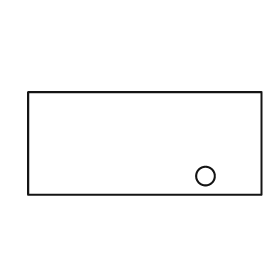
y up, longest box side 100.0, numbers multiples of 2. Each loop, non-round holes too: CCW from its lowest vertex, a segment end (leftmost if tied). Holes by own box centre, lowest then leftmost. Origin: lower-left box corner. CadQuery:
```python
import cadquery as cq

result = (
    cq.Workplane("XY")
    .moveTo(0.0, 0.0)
    .lineTo(100.0, 0.0)
    .lineTo(100.0, 44.0)
    .lineTo(0.0, 44.0)
    .close()
    .moveTo(76.0, 8.0)
    .circle(4.0)
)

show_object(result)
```